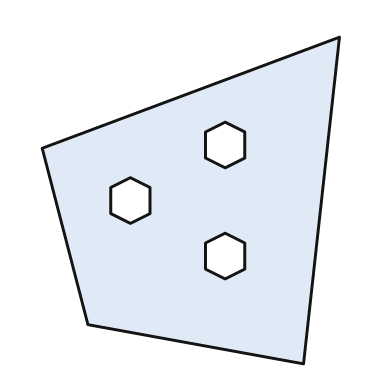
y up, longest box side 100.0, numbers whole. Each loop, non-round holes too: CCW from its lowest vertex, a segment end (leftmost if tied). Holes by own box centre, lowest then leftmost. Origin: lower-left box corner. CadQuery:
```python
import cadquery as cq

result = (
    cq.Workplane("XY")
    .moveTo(80.0, 0.0)
    .lineTo(91.0, 100.0)
    .lineTo(0.0, 66.0)
    .lineTo(14.0, 12.0)
    .close()
    .moveTo(56.0, 26.0)
    .lineTo(62.0, 29.0)
    .lineTo(62.0, 37.0)
    .lineTo(56.0, 40.0)
    .lineTo(50.0, 37.0)
    .lineTo(50.0, 29.0)
    .close()
    .moveTo(27.0, 43.0)
    .lineTo(33.0, 46.0)
    .lineTo(33.0, 54.0)
    .lineTo(27.0, 57.0)
    .lineTo(21.0, 54.0)
    .lineTo(21.0, 46.0)
    .close()
    .moveTo(56.0, 60.0)
    .lineTo(62.0, 63.0)
    .lineTo(62.0, 71.0)
    .lineTo(56.0, 74.0)
    .lineTo(50.0, 71.0)
    .lineTo(50.0, 63.0)
    .close()
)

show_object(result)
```